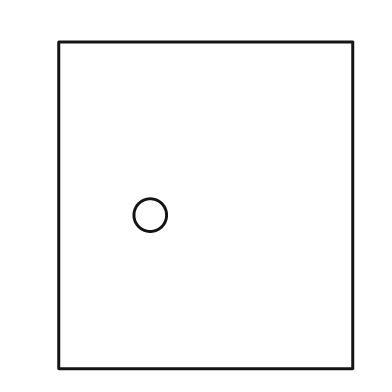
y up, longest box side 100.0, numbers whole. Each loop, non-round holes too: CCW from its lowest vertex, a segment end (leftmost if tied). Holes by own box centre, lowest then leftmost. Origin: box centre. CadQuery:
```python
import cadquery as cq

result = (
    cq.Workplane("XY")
    .moveTo(-45.0, -50.0)
    .lineTo(45.0, -50.0)
    .lineTo(45.0, 50.0)
    .lineTo(-45.0, 50.0)
    .close()
    .moveTo(-17.0, -3.0)
    .circle(5.0)
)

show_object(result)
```